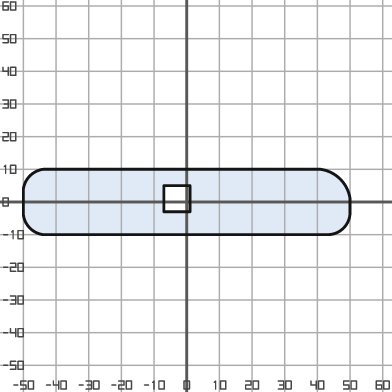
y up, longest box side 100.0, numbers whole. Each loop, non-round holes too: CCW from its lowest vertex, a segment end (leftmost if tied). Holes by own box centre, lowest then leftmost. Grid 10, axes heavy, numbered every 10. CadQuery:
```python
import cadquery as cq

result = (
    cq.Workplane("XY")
    .moveTo(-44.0, -10.0)
    .lineTo(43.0, -10.0)
    .threePointArc((48.0, -8.0), (50.0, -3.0))
    .lineTo(50.0, 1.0)
    .threePointArc((47.0, 7.0), (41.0, 10.0))
    .lineTo(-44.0, 10.0)
    .threePointArc((-48.0, 8.0), (-50.0, 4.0))
    .lineTo(-50.0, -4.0)
    .threePointArc((-48.0, -8.0), (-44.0, -10.0))
    .close()
    .moveTo(-7.0, -3.0)
    .lineTo(1.0, -3.0)
    .lineTo(1.0, 5.0)
    .lineTo(-7.0, 5.0)
    .close()
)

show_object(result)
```